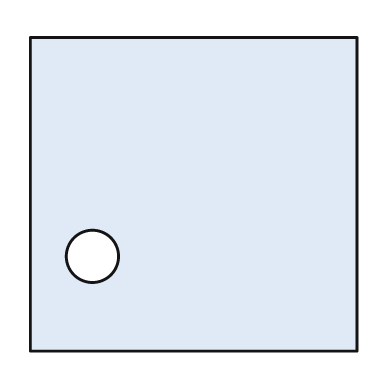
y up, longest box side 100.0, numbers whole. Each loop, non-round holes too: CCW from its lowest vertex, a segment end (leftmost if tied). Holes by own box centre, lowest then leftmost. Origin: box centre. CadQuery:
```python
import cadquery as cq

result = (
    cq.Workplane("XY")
    .moveTo(-50.0, -48.0)
    .lineTo(50.0, -48.0)
    .lineTo(50.0, 48.0)
    .lineTo(-50.0, 48.0)
    .close()
    .moveTo(-31.0, -19.0)
    .circle(8.0)
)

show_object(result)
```